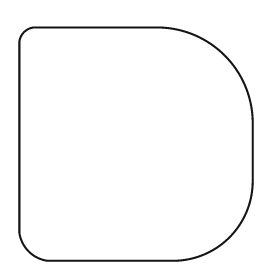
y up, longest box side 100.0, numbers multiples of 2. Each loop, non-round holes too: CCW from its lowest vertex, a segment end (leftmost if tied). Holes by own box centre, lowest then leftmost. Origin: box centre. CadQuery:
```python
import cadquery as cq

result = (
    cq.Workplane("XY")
    .moveTo(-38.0, -50.0)
    .lineTo(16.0, -50.0)
    .threePointArc((40.0, -40.0), (50.0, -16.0))
    .lineTo(50.0, 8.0)
    .threePointArc((38.0, 38.0), (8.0, 50.0))
    .lineTo(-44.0, 50.0)
    .threePointArc((-48.0, 48.0), (-50.0, 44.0))
    .lineTo(-50.0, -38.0)
    .threePointArc((-46.0, -46.0), (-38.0, -50.0))
    .close()
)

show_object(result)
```